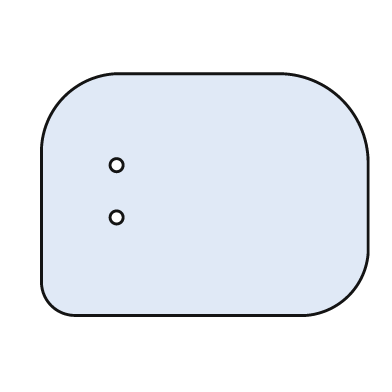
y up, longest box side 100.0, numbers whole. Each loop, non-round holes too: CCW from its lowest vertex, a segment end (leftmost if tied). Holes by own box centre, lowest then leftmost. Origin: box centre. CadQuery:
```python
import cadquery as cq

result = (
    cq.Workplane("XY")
    .moveTo(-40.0, -37.0)
    .lineTo(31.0, -37.0)
    .threePointArc((44.0, -31.0), (50.0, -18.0))
    .lineTo(50.0, 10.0)
    .threePointArc((42.0, 29.0), (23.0, 37.0))
    .lineTo(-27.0, 37.0)
    .threePointArc((-43.0, 30.0), (-50.0, 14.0))
    .lineTo(-50.0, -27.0)
    .threePointArc((-47.0, -34.0), (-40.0, -37.0))
    .close()
    .moveTo(-27.0, -7.0)
    .circle(2.0)
    .moveTo(-27.0, 9.0)
    .circle(2.0)
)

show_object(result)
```